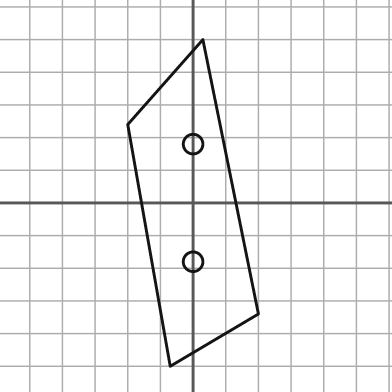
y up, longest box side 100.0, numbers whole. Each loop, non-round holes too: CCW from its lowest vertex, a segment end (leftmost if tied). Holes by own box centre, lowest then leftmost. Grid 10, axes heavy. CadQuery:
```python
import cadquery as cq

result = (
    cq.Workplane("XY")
    .moveTo(-7.0, -50.0)
    .lineTo(20.0, -34.0)
    .lineTo(3.0, 50.0)
    .lineTo(-20.0, 24.0)
    .close()
    .moveTo(0.0, -18.0)
    .circle(3.0)
    .moveTo(0.0, 18.0)
    .circle(3.0)
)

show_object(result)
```